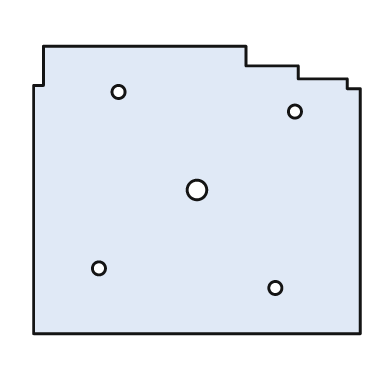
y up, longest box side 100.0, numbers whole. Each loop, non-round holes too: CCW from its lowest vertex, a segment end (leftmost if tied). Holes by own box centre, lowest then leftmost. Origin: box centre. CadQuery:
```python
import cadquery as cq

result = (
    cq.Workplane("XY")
    .moveTo(-50.0, -44.0)
    .lineTo(50.0, -44.0)
    .lineTo(50.0, 31.0)
    .lineTo(46.0, 31.0)
    .lineTo(46.0, 34.0)
    .lineTo(31.0, 34.0)
    .lineTo(31.0, 38.0)
    .lineTo(15.0, 38.0)
    .lineTo(15.0, 44.0)
    .lineTo(-47.0, 44.0)
    .lineTo(-47.0, 32.0)
    .lineTo(-50.0, 32.0)
    .close()
    .moveTo(24.0, -30.0)
    .circle(2.0)
    .moveTo(-30.0, -24.0)
    .circle(2.0)
    .moveTo(0.0, 0.0)
    .circle(3.0)
    .moveTo(30.0, 24.0)
    .circle(2.0)
    .moveTo(-24.0, 30.0)
    .circle(2.0)
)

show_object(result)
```